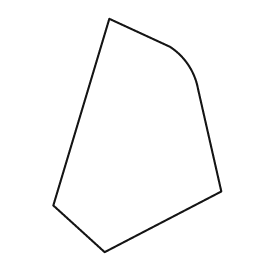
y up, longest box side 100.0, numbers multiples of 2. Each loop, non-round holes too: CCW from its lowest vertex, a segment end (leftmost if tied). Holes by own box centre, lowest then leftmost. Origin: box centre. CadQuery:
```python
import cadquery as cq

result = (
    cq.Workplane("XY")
    .moveTo(-14.0, -50.0)
    .lineTo(36.0, -24.0)
    .lineTo(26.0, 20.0)
    .threePointArc((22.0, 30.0), (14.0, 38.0))
    .lineTo(-12.0, 50.0)
    .lineTo(-36.0, -30.0)
    .close()
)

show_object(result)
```